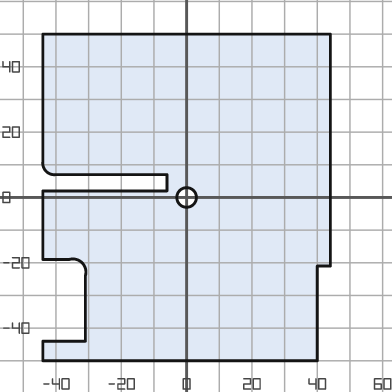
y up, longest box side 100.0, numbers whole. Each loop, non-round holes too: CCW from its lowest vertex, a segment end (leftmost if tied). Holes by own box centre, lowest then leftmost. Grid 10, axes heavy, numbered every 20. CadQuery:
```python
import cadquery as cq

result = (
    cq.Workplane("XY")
    .moveTo(-44.0, -50.0)
    .lineTo(40.0, -50.0)
    .lineTo(40.0, -21.0)
    .lineTo(44.0, -21.0)
    .lineTo(44.0, 50.0)
    .lineTo(-44.0, 50.0)
    .lineTo(-44.0, 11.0)
    .threePointArc((-43.0, 8.0), (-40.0, 7.0))
    .lineTo(-6.0, 7.0)
    .lineTo(-6.0, 2.0)
    .lineTo(-44.0, 2.0)
    .lineTo(-44.0, -19.0)
    .lineTo(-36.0, -19.0)
    .threePointArc((-32.0, -20.0), (-31.0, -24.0))
    .lineTo(-31.0, -44.0)
    .lineTo(-44.0, -44.0)
    .close()
    .moveTo(0.0, 0.0)
    .circle(3.0)
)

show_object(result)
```